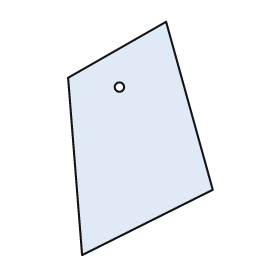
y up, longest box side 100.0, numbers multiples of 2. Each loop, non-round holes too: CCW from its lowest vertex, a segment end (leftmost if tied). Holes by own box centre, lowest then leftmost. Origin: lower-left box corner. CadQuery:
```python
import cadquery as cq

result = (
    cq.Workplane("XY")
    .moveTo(6.0, 0.0)
    .lineTo(62.0, 28.0)
    .lineTo(42.0, 100.0)
    .lineTo(0.0, 76.0)
    .close()
    .moveTo(22.0, 72.0)
    .circle(2.0)
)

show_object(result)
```